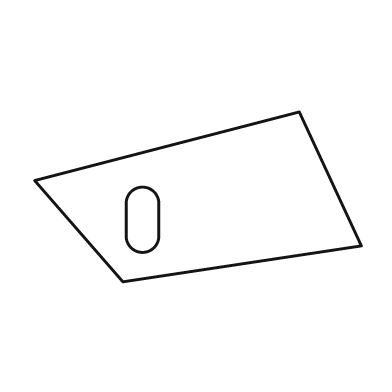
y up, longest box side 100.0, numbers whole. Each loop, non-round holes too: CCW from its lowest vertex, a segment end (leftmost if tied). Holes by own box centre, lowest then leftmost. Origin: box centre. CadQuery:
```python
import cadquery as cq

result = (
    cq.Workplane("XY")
    .moveTo(-23.0, -26.0)
    .lineTo(50.0, -15.0)
    .lineTo(31.0, 26.0)
    .lineTo(-50.0, 5.0)
    .close()
    .moveTo(-22.0, -12.0)
    .threePointArc((-17.0, -17.0), (-12.0, -12.0))
    .lineTo(-12.0, -2.0)
    .threePointArc((-17.0, 3.0), (-22.0, -2.0))
    .close()
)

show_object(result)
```